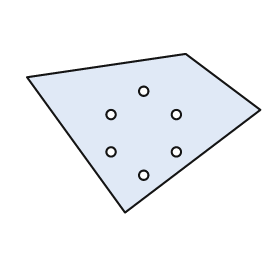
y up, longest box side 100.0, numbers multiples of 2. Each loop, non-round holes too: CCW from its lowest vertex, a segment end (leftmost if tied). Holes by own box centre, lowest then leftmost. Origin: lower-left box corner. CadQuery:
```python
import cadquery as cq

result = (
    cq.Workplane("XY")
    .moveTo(42.0, 0.0)
    .lineTo(100.0, 44.0)
    .lineTo(68.0, 68.0)
    .lineTo(0.0, 58.0)
    .close()
    .moveTo(50.0, 16.0)
    .circle(2.0)
    .moveTo(36.0, 26.0)
    .circle(2.0)
    .moveTo(64.0, 26.0)
    .circle(2.0)
    .moveTo(36.0, 42.0)
    .circle(2.0)
    .moveTo(64.0, 42.0)
    .circle(2.0)
    .moveTo(50.0, 52.0)
    .circle(2.0)
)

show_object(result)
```